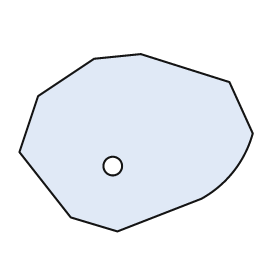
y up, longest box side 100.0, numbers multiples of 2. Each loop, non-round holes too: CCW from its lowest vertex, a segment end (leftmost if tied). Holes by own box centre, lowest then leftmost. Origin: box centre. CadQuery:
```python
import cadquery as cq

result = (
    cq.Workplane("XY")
    .moveTo(-8.0, -38.0)
    .lineTo(28.0, -24.0)
    .threePointArc((42.0, -12.0), (50.0, 4.0))
    .lineTo(40.0, 26.0)
    .lineTo(2.0, 38.0)
    .lineTo(-18.0, 36.0)
    .lineTo(-42.0, 20.0)
    .lineTo(-50.0, -4.0)
    .lineTo(-28.0, -32.0)
    .close()
    .moveTo(-10.0, -10.0)
    .circle(4.0)
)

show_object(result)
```